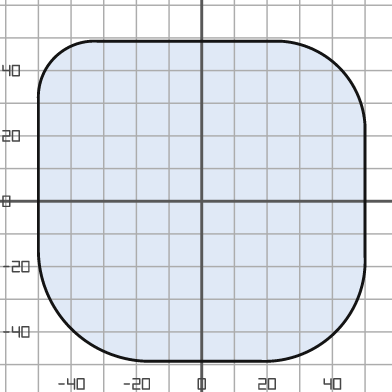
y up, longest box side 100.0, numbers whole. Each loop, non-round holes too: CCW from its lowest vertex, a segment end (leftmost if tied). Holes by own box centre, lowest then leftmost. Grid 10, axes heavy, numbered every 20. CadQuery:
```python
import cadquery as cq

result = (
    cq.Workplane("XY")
    .moveTo(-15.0, -49.0)
    .lineTo(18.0, -49.0)
    .threePointArc((41.0, -40.0), (50.0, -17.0))
    .lineTo(50.0, 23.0)
    .threePointArc((42.0, 41.0), (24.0, 49.0))
    .lineTo(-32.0, 49.0)
    .threePointArc((-45.0, 44.0), (-50.0, 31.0))
    .lineTo(-50.0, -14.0)
    .threePointArc((-40.0, -39.0), (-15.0, -49.0))
    .close()
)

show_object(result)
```